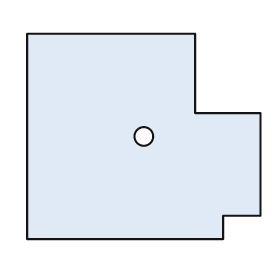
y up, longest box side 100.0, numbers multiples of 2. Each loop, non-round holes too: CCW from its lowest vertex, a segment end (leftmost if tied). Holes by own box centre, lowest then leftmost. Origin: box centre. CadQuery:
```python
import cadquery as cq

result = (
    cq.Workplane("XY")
    .moveTo(-50.0, -44.0)
    .lineTo(34.0, -44.0)
    .lineTo(34.0, -34.0)
    .lineTo(50.0, -34.0)
    .lineTo(50.0, 10.0)
    .lineTo(22.0, 10.0)
    .lineTo(22.0, 44.0)
    .lineTo(-50.0, 44.0)
    .close()
    .moveTo(0.0, 0.0)
    .circle(4.0)
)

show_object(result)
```